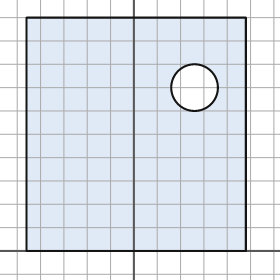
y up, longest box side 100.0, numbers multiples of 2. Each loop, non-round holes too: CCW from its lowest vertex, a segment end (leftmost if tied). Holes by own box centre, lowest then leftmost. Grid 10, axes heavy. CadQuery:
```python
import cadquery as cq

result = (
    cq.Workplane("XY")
    .moveTo(-46.0, 0.0)
    .lineTo(48.0, 0.0)
    .lineTo(48.0, 100.0)
    .lineTo(-46.0, 100.0)
    .close()
    .moveTo(26.0, 70.0)
    .circle(10.0)
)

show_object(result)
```